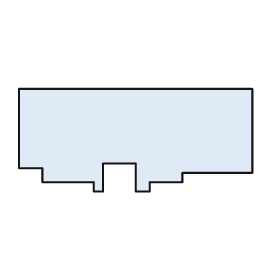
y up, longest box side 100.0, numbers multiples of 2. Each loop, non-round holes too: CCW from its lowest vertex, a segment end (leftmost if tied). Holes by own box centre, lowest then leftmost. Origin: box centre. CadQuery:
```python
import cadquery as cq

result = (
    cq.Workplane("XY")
    .moveTo(-18.0, -22.0)
    .lineTo(-14.0, -22.0)
    .lineTo(-14.0, -10.0)
    .lineTo(0.0, -10.0)
    .lineTo(0.0, -22.0)
    .lineTo(6.0, -22.0)
    .lineTo(6.0, -18.0)
    .lineTo(20.0, -18.0)
    .lineTo(20.0, -14.0)
    .lineTo(50.0, -14.0)
    .lineTo(50.0, 22.0)
    .lineTo(-50.0, 22.0)
    .lineTo(-50.0, -12.0)
    .lineTo(-40.0, -12.0)
    .lineTo(-40.0, -18.0)
    .lineTo(-18.0, -18.0)
    .close()
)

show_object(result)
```